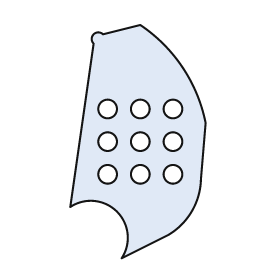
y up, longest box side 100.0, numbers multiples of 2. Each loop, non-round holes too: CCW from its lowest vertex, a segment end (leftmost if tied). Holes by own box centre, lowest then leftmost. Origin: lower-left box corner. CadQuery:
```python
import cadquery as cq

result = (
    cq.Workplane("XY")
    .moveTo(22.0, 0.0)
    .lineTo(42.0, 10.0)
    .threePointArc((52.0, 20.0), (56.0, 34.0))
    .lineTo(58.0, 58.0)
    .threePointArc((48.0, 82.0), (30.0, 100.0))
    .lineTo(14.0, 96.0)
    .threePointArc((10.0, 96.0), (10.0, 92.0))
    .lineTo(0.0, 22.0)
    .threePointArc((20.0, 20.0), (22.0, 0.0))
    .close()
    .moveTo(16.0, 36.0)
    .circle(4.0)
    .moveTo(30.0, 36.0)
    .circle(4.0)
    .moveTo(44.0, 36.0)
    .circle(4.0)
    .moveTo(16.0, 50.0)
    .circle(4.0)
    .moveTo(30.0, 50.0)
    .circle(4.0)
    .moveTo(44.0, 50.0)
    .circle(4.0)
    .moveTo(16.0, 64.0)
    .circle(4.0)
    .moveTo(30.0, 64.0)
    .circle(4.0)
    .moveTo(44.0, 64.0)
    .circle(4.0)
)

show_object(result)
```